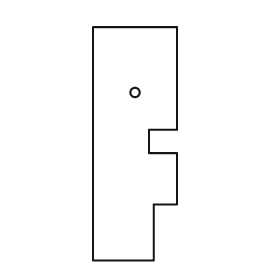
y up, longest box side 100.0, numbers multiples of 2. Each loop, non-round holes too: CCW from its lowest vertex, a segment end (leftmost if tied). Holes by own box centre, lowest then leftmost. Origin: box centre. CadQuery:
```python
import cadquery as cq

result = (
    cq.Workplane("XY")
    .moveTo(-18.0, -50.0)
    .lineTo(8.0, -50.0)
    .lineTo(8.0, -26.0)
    .lineTo(18.0, -26.0)
    .lineTo(18.0, -4.0)
    .lineTo(6.0, -4.0)
    .lineTo(6.0, 6.0)
    .lineTo(18.0, 6.0)
    .lineTo(18.0, 50.0)
    .lineTo(-18.0, 50.0)
    .close()
    .moveTo(0.0, 22.0)
    .circle(2.0)
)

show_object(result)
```